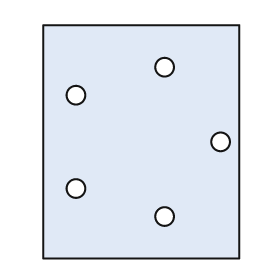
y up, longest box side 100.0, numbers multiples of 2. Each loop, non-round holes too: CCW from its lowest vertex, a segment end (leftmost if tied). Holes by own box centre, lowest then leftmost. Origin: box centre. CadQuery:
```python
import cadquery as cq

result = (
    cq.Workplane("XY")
    .moveTo(-42.0, -50.0)
    .lineTo(42.0, -50.0)
    .lineTo(42.0, 50.0)
    .lineTo(-42.0, 50.0)
    .close()
    .moveTo(10.0, -32.0)
    .circle(4.0)
    .moveTo(-28.0, -20.0)
    .circle(4.0)
    .moveTo(34.0, 0.0)
    .circle(4.0)
    .moveTo(-28.0, 20.0)
    .circle(4.0)
    .moveTo(10.0, 32.0)
    .circle(4.0)
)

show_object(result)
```